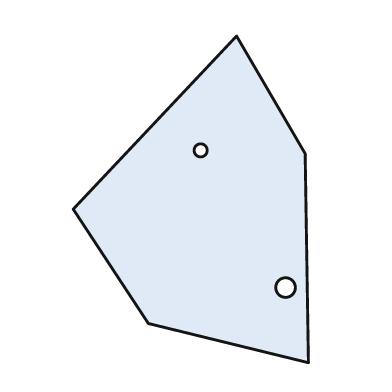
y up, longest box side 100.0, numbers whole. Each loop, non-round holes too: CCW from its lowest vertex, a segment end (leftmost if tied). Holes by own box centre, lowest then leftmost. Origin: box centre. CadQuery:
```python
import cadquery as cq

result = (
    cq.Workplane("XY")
    .moveTo(36.0, -50.0)
    .lineTo(35.0, 14.0)
    .lineTo(14.0, 50.0)
    .lineTo(-36.0, -3.0)
    .lineTo(-13.0, -38.0)
    .close()
    .moveTo(29.0, -27.0)
    .circle(3.0)
    .moveTo(3.0, 15.0)
    .circle(2.0)
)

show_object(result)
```